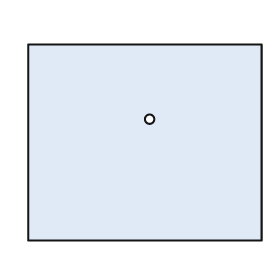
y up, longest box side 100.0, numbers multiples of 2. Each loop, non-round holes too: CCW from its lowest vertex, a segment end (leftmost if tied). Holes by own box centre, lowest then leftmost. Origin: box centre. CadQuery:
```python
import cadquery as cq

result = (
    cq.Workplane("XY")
    .moveTo(-50.0, -42.0)
    .lineTo(50.0, -42.0)
    .lineTo(50.0, 42.0)
    .lineTo(-50.0, 42.0)
    .close()
    .moveTo(2.0, 10.0)
    .circle(2.0)
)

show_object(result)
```